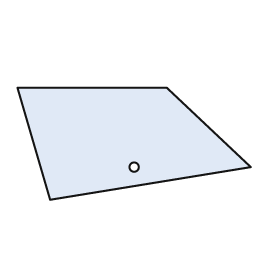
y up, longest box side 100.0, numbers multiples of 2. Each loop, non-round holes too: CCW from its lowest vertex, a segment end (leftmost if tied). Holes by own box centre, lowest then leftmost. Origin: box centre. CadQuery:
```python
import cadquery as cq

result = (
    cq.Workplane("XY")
    .moveTo(-36.0, -24.0)
    .lineTo(50.0, -10.0)
    .lineTo(14.0, 24.0)
    .lineTo(-50.0, 24.0)
    .close()
    .moveTo(0.0, -10.0)
    .circle(2.0)
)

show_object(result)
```